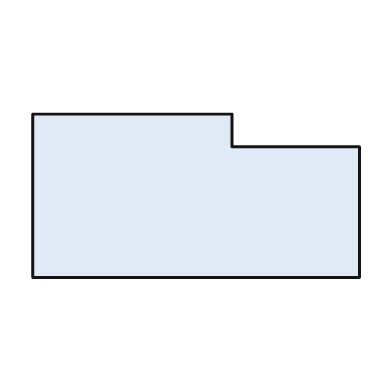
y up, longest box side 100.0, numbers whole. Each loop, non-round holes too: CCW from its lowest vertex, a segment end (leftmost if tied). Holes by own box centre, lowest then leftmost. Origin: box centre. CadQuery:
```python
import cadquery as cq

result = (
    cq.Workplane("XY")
    .moveTo(-50.0, -25.0)
    .lineTo(50.0, -25.0)
    .lineTo(50.0, 15.0)
    .lineTo(11.0, 15.0)
    .lineTo(11.0, 25.0)
    .lineTo(-50.0, 25.0)
    .close()
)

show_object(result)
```